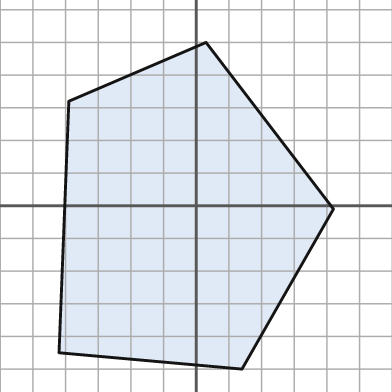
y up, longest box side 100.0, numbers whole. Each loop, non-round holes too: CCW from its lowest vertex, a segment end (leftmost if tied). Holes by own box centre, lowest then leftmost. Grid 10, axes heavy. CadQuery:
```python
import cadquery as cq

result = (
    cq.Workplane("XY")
    .moveTo(14.0, -50.0)
    .lineTo(42.0, -1.0)
    .lineTo(3.0, 50.0)
    .lineTo(-39.0, 32.0)
    .lineTo(-42.0, -45.0)
    .close()
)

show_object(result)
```